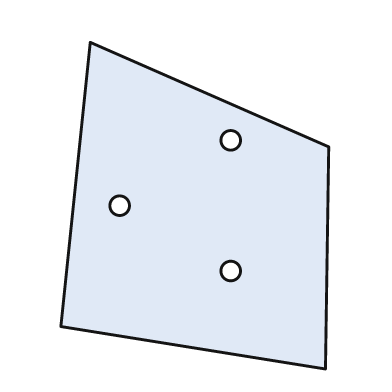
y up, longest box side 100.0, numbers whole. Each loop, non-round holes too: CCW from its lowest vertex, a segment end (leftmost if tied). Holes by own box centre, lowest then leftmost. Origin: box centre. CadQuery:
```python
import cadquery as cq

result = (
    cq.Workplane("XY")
    .moveTo(40.0, -50.0)
    .lineTo(41.0, 18.0)
    .lineTo(-32.0, 50.0)
    .lineTo(-41.0, -37.0)
    .close()
    .moveTo(11.0, -20.0)
    .circle(3.0)
    .moveTo(-23.0, 0.0)
    .circle(3.0)
    .moveTo(11.0, 20.0)
    .circle(3.0)
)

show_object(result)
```